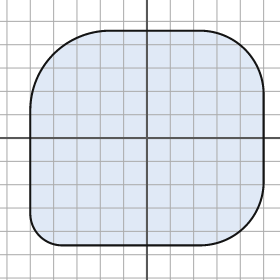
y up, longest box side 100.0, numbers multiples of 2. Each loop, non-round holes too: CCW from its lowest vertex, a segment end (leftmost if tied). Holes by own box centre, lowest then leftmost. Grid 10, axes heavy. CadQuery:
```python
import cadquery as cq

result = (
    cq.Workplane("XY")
    .moveTo(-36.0, -46.0)
    .lineTo(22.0, -46.0)
    .threePointArc((42.0, -38.0), (50.0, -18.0))
    .lineTo(50.0, 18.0)
    .threePointArc((42.0, 38.0), (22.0, 46.0))
    .lineTo(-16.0, 46.0)
    .threePointArc((-40.0, 36.0), (-50.0, 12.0))
    .lineTo(-50.0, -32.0)
    .threePointArc((-46.0, -42.0), (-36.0, -46.0))
    .close()
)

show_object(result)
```